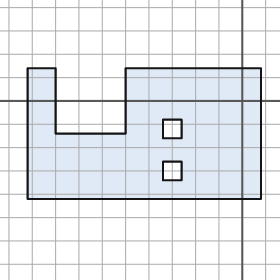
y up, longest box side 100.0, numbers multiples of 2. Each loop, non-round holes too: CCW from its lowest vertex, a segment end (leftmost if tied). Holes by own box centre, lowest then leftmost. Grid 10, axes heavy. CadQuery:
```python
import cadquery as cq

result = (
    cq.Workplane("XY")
    .moveTo(-92.0, -42.0)
    .lineTo(8.0, -42.0)
    .lineTo(8.0, 14.0)
    .lineTo(-50.0, 14.0)
    .lineTo(-50.0, -14.0)
    .lineTo(-80.0, -14.0)
    .lineTo(-80.0, 14.0)
    .lineTo(-92.0, 14.0)
    .close()
    .moveTo(-34.0, -34.0)
    .lineTo(-26.0, -34.0)
    .lineTo(-26.0, -26.0)
    .lineTo(-34.0, -26.0)
    .close()
    .moveTo(-34.0, -16.0)
    .lineTo(-26.0, -16.0)
    .lineTo(-26.0, -8.0)
    .lineTo(-34.0, -8.0)
    .close()
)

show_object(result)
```